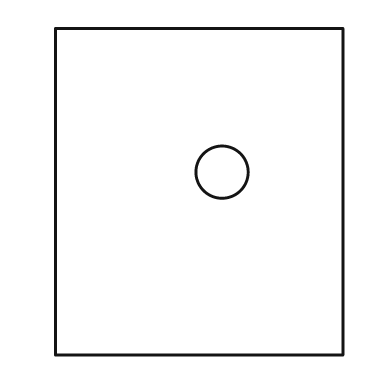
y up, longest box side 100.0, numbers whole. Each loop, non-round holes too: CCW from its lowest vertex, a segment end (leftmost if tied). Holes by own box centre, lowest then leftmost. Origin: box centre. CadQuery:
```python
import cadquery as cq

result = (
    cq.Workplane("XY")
    .moveTo(-44.0, -50.0)
    .lineTo(44.0, -50.0)
    .lineTo(44.0, 50.0)
    .lineTo(-44.0, 50.0)
    .close()
    .moveTo(7.0, 6.0)
    .circle(8.0)
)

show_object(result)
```